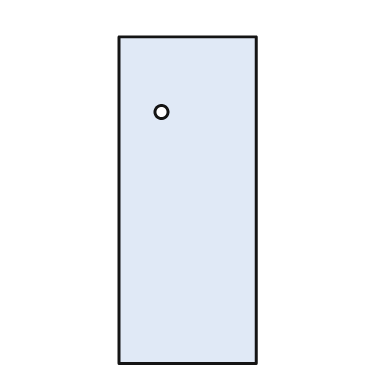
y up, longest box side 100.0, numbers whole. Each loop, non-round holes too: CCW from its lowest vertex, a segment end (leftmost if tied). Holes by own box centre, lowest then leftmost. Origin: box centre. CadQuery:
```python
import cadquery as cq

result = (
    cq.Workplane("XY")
    .moveTo(-21.0, -50.0)
    .lineTo(21.0, -50.0)
    .lineTo(21.0, 50.0)
    .lineTo(-21.0, 50.0)
    .close()
    .moveTo(-8.0, 27.0)
    .circle(2.0)
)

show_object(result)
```